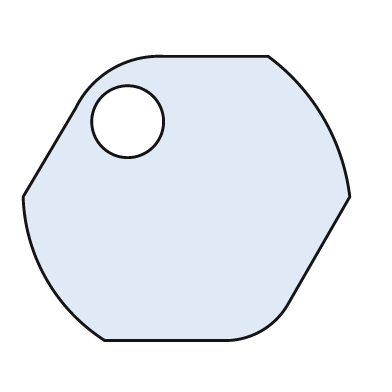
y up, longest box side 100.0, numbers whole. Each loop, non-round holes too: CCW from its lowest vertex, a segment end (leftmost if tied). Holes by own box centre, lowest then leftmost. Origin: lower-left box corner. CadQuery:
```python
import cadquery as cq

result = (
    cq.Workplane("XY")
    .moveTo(25.0, 0.0)
    .lineTo(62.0, 0.0)
    .threePointArc((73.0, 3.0), (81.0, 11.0))
    .lineTo(100.0, 44.0)
    .threePointArc((92.0, 68.0), (75.0, 87.0))
    .lineTo(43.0, 87.0)
    .threePointArc((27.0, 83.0), (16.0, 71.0))
    .lineTo(0.0, 44.0)
    .threePointArc((7.0, 19.0), (25.0, 0.0))
    .close()
    .moveTo(32.0, 67.0)
    .circle(11.0)
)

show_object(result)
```